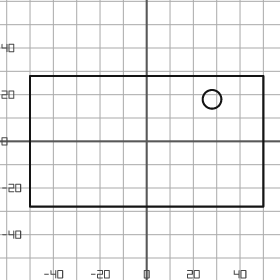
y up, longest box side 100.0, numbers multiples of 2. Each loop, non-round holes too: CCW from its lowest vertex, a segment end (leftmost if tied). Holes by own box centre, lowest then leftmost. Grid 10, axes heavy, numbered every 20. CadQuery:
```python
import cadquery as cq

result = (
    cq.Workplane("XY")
    .moveTo(-50.0, -28.0)
    .lineTo(50.0, -28.0)
    .lineTo(50.0, 28.0)
    .lineTo(-50.0, 28.0)
    .close()
    .moveTo(28.0, 18.0)
    .circle(4.0)
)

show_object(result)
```